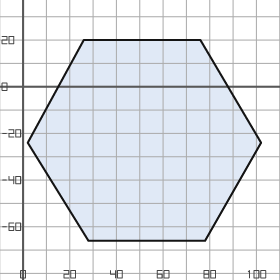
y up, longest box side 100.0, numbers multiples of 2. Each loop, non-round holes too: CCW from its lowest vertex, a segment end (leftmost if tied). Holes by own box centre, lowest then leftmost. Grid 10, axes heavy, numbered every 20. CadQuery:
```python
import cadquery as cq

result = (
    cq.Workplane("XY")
    .moveTo(28.0, -66.0)
    .lineTo(78.0, -66.0)
    .lineTo(102.0, -24.0)
    .lineTo(76.0, 20.0)
    .lineTo(26.0, 20.0)
    .lineTo(2.0, -24.0)
    .close()
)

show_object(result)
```